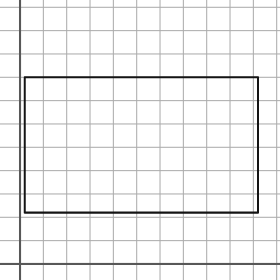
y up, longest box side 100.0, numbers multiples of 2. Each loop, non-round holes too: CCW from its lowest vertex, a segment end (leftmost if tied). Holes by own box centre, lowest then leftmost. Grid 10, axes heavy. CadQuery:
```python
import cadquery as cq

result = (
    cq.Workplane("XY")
    .moveTo(2.0, 22.0)
    .lineTo(102.0, 22.0)
    .lineTo(102.0, 80.0)
    .lineTo(2.0, 80.0)
    .close()
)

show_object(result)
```